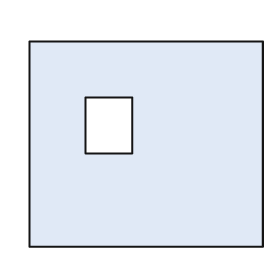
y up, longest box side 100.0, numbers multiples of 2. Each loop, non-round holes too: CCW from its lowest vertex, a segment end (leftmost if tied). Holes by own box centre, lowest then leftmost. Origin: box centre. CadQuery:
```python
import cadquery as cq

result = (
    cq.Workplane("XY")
    .moveTo(-50.0, -44.0)
    .lineTo(50.0, -44.0)
    .lineTo(50.0, 44.0)
    .lineTo(-50.0, 44.0)
    .close()
    .moveTo(-26.0, -4.0)
    .lineTo(-6.0, -4.0)
    .lineTo(-6.0, 20.0)
    .lineTo(-26.0, 20.0)
    .close()
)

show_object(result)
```